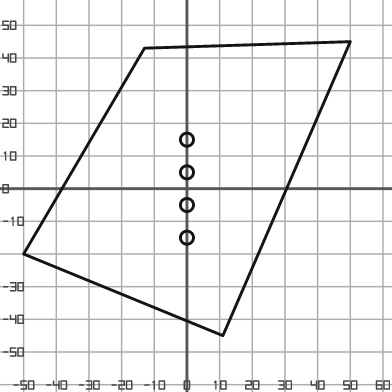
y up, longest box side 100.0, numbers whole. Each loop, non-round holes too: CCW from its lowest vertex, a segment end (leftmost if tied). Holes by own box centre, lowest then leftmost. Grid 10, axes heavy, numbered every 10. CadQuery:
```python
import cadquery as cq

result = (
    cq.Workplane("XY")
    .moveTo(11.0, -45.0)
    .lineTo(50.0, 45.0)
    .lineTo(-13.0, 43.0)
    .lineTo(-50.0, -20.0)
    .close()
    .moveTo(0.0, -15.0)
    .circle(2.0)
    .moveTo(0.0, -5.0)
    .circle(2.0)
    .moveTo(0.0, 5.0)
    .circle(2.0)
    .moveTo(0.0, 15.0)
    .circle(2.0)
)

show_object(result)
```